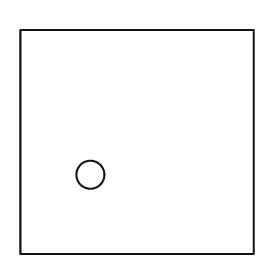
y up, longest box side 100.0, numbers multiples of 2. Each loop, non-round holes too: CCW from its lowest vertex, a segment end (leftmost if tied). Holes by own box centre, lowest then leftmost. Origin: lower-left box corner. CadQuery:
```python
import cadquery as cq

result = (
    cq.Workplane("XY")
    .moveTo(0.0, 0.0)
    .lineTo(100.0, 0.0)
    .lineTo(100.0, 96.0)
    .lineTo(0.0, 96.0)
    .close()
    .moveTo(30.0, 34.0)
    .circle(6.0)
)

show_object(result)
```